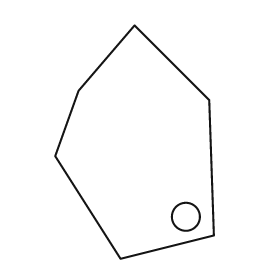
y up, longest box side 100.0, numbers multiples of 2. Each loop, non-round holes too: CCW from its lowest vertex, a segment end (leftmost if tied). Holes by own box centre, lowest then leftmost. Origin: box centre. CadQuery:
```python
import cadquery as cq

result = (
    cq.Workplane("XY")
    .moveTo(-6.0, -50.0)
    .lineTo(34.0, -40.0)
    .lineTo(32.0, 18.0)
    .lineTo(0.0, 50.0)
    .lineTo(-24.0, 22.0)
    .lineTo(-34.0, -6.0)
    .close()
    .moveTo(22.0, -32.0)
    .circle(6.0)
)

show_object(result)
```